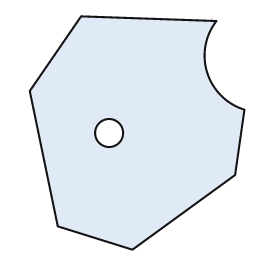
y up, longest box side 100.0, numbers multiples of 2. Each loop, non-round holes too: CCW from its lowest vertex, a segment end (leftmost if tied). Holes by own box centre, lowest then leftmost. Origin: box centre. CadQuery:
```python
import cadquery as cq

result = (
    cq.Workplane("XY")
    .moveTo(-2.0, -50.0)
    .lineTo(42.0, -18.0)
    .lineTo(46.0, 10.0)
    .threePointArc((30.0, 26.0), (34.0, 48.0))
    .lineTo(-24.0, 50.0)
    .lineTo(-46.0, 18.0)
    .lineTo(-34.0, -40.0)
    .close()
    .moveTo(-12.0, 0.0)
    .circle(6.0)
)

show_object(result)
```